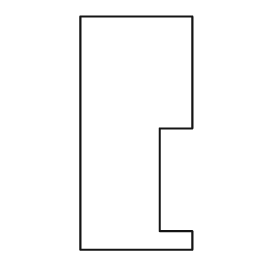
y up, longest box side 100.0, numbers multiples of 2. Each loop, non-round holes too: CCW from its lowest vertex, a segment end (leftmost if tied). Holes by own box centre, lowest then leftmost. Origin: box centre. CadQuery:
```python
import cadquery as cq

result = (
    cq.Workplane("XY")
    .moveTo(-24.0, -50.0)
    .lineTo(24.0, -50.0)
    .lineTo(24.0, -42.0)
    .lineTo(10.0, -42.0)
    .lineTo(10.0, 2.0)
    .lineTo(24.0, 2.0)
    .lineTo(24.0, 50.0)
    .lineTo(-24.0, 50.0)
    .close()
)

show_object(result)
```